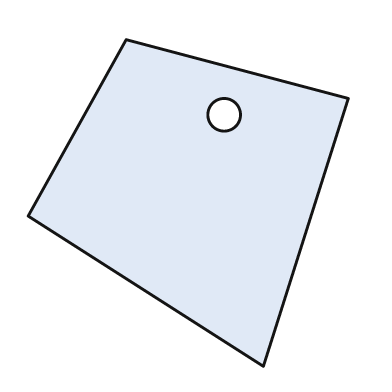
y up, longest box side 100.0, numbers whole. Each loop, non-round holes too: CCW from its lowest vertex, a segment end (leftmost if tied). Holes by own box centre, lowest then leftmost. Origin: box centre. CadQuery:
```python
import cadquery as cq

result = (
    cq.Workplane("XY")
    .moveTo(23.0, -50.0)
    .lineTo(49.0, 32.0)
    .lineTo(-19.0, 50.0)
    .lineTo(-49.0, -4.0)
    .close()
    .moveTo(11.0, 27.0)
    .circle(5.0)
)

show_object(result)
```